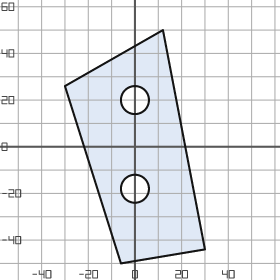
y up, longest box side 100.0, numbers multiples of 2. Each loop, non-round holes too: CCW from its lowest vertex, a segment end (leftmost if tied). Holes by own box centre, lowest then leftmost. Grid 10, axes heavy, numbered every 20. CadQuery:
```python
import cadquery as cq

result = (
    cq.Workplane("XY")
    .moveTo(-6.0, -50.0)
    .lineTo(30.0, -44.0)
    .lineTo(12.0, 50.0)
    .lineTo(-30.0, 26.0)
    .close()
    .moveTo(0.0, -18.0)
    .circle(6.0)
    .moveTo(0.0, 20.0)
    .circle(6.0)
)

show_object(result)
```